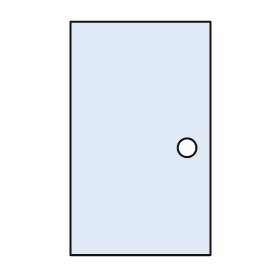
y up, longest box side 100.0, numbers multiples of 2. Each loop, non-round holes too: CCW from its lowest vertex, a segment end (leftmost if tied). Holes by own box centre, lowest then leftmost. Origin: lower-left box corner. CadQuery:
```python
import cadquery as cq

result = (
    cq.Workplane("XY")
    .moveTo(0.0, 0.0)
    .lineTo(60.0, 0.0)
    .lineTo(60.0, 100.0)
    .lineTo(0.0, 100.0)
    .close()
    .moveTo(50.0, 46.0)
    .circle(4.0)
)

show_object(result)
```